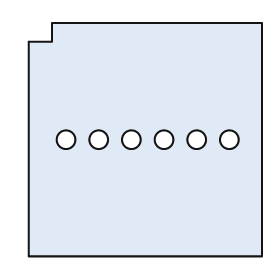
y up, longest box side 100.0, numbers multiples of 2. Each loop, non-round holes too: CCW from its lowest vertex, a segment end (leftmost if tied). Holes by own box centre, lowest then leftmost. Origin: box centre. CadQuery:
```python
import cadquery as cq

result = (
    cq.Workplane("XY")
    .moveTo(-50.0, -50.0)
    .lineTo(50.0, -50.0)
    .lineTo(50.0, 50.0)
    .lineTo(-40.0, 50.0)
    .lineTo(-40.0, 42.0)
    .lineTo(-50.0, 42.0)
    .close()
    .moveTo(-34.0, 0.0)
    .circle(4.0)
    .moveTo(-20.0, 0.0)
    .circle(4.0)
    .moveTo(-6.0, 0.0)
    .circle(4.0)
    .moveTo(8.0, 0.0)
    .circle(4.0)
    .moveTo(22.0, 0.0)
    .circle(4.0)
    .moveTo(36.0, 0.0)
    .circle(4.0)
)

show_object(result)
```